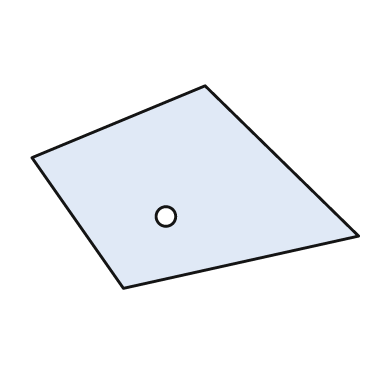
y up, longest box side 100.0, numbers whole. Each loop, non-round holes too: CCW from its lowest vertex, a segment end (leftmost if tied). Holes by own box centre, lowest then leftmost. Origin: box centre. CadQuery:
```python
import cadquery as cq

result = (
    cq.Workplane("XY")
    .moveTo(-22.0, -31.0)
    .lineTo(50.0, -15.0)
    .lineTo(3.0, 31.0)
    .lineTo(-50.0, 9.0)
    .close()
    .moveTo(-9.0, -9.0)
    .circle(3.0)
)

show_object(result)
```